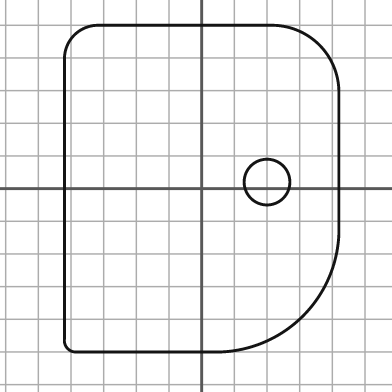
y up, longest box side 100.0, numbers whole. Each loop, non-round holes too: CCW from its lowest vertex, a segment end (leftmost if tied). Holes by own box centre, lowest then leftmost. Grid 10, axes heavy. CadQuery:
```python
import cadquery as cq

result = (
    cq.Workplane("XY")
    .moveTo(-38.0, -50.0)
    .lineTo(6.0, -50.0)
    .threePointArc((31.0, -39.0), (42.0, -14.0))
    .lineTo(42.0, 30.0)
    .threePointArc((36.0, 44.0), (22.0, 50.0))
    .lineTo(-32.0, 50.0)
    .threePointArc((-39.0, 47.0), (-42.0, 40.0))
    .lineTo(-42.0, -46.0)
    .threePointArc((-41.0, -49.0), (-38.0, -50.0))
    .close()
    .moveTo(20.0, 2.0)
    .circle(7.0)
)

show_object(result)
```